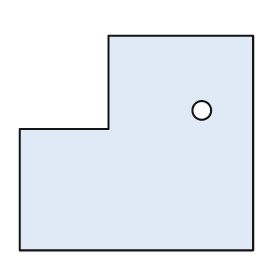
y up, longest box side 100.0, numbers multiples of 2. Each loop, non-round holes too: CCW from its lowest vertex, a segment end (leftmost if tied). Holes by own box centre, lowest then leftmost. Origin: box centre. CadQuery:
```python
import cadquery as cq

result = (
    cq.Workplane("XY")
    .moveTo(-50.0, -46.0)
    .lineTo(50.0, -46.0)
    .lineTo(50.0, 46.0)
    .lineTo(-12.0, 46.0)
    .lineTo(-12.0, 6.0)
    .lineTo(-50.0, 6.0)
    .close()
    .moveTo(28.0, 14.0)
    .circle(4.0)
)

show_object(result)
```